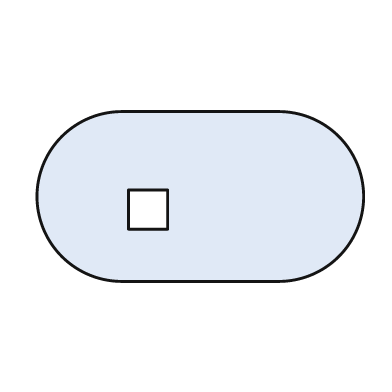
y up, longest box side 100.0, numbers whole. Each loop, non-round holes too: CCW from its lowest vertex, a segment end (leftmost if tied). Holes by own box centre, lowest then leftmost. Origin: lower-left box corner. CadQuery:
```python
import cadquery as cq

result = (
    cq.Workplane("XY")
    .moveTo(26.0, 0.0)
    .lineTo(74.0, 0.0)
    .threePointArc((100.0, 26.0), (74.0, 52.0))
    .lineTo(26.0, 52.0)
    .threePointArc((0.0, 26.0), (26.0, 0.0))
    .close()
    .moveTo(28.0, 16.0)
    .lineTo(40.0, 16.0)
    .lineTo(40.0, 28.0)
    .lineTo(28.0, 28.0)
    .close()
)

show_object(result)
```